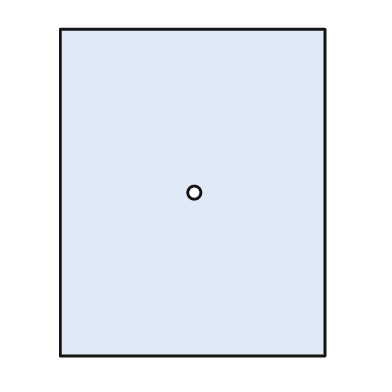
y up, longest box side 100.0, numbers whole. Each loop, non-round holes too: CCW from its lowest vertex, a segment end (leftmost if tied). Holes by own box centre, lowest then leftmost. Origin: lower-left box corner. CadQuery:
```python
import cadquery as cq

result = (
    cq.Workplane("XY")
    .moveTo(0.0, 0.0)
    .lineTo(81.0, 0.0)
    .lineTo(81.0, 100.0)
    .lineTo(0.0, 100.0)
    .close()
    .moveTo(41.0, 50.0)
    .circle(2.0)
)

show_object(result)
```